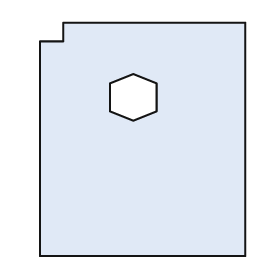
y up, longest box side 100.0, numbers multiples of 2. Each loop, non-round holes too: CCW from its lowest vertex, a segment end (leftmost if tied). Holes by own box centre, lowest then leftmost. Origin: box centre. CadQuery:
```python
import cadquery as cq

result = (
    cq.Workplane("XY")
    .moveTo(-44.0, -50.0)
    .lineTo(44.0, -50.0)
    .lineTo(44.0, 50.0)
    .lineTo(-34.0, 50.0)
    .lineTo(-34.0, 42.0)
    .lineTo(-44.0, 42.0)
    .close()
    .moveTo(-4.0, 8.0)
    .lineTo(6.0, 12.0)
    .lineTo(6.0, 24.0)
    .lineTo(-4.0, 28.0)
    .lineTo(-14.0, 24.0)
    .lineTo(-14.0, 12.0)
    .close()
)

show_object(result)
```